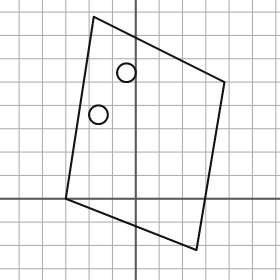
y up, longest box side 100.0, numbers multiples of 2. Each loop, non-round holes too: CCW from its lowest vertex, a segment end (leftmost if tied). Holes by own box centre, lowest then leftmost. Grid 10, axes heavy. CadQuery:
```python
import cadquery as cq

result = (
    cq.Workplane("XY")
    .moveTo(26.0, -22.0)
    .lineTo(38.0, 50.0)
    .lineTo(-18.0, 78.0)
    .lineTo(-30.0, 0.0)
    .close()
    .moveTo(-16.0, 36.0)
    .circle(4.0)
    .moveTo(-4.0, 54.0)
    .circle(4.0)
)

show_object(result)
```